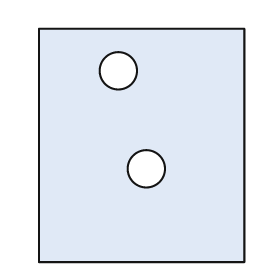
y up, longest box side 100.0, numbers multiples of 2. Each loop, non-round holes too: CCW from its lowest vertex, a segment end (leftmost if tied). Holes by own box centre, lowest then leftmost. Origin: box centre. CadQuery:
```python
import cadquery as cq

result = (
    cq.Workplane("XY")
    .moveTo(-44.0, -50.0)
    .lineTo(44.0, -50.0)
    .lineTo(44.0, 50.0)
    .lineTo(-44.0, 50.0)
    .close()
    .moveTo(2.0, -10.0)
    .circle(8.0)
    .moveTo(-10.0, 32.0)
    .circle(8.0)
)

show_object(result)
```